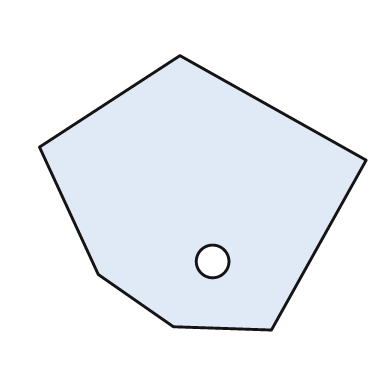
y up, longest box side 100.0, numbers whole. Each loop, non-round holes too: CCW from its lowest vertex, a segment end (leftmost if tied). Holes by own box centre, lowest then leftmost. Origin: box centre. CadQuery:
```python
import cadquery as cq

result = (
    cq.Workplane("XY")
    .moveTo(21.0, -42.0)
    .lineTo(50.0, 10.0)
    .lineTo(-7.0, 42.0)
    .lineTo(-50.0, 14.0)
    .lineTo(-32.0, -25.0)
    .lineTo(-9.0, -41.0)
    .close()
    .moveTo(3.0, -21.0)
    .circle(5.0)
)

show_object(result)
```